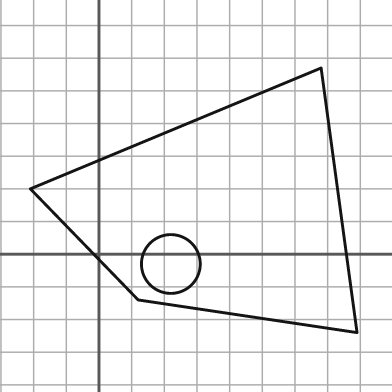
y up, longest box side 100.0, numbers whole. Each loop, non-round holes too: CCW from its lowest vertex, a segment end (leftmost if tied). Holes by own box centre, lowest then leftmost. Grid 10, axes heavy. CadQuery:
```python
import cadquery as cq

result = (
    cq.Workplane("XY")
    .moveTo(79.0, -24.0)
    .lineTo(68.0, 57.0)
    .lineTo(-21.0, 20.0)
    .lineTo(12.0, -14.0)
    .close()
    .moveTo(22.0, -3.0)
    .circle(9.0)
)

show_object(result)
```